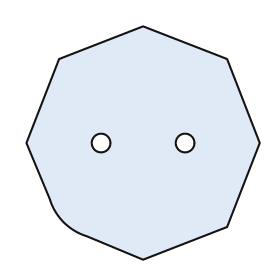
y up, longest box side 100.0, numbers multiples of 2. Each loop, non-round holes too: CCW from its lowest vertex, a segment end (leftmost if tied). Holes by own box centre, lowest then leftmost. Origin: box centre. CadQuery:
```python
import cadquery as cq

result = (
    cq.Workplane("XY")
    .moveTo(0.0, -50.0)
    .lineTo(36.0, -36.0)
    .lineTo(50.0, 0.0)
    .lineTo(36.0, 36.0)
    .lineTo(0.0, 50.0)
    .lineTo(-36.0, 36.0)
    .lineTo(-50.0, 0.0)
    .lineTo(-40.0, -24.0)
    .threePointArc((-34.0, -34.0), (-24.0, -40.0))
    .close()
    .moveTo(-18.0, 0.0)
    .circle(4.0)
    .moveTo(18.0, 0.0)
    .circle(4.0)
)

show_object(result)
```